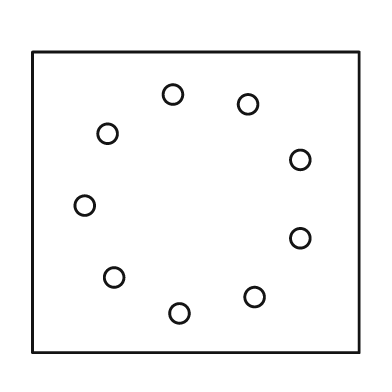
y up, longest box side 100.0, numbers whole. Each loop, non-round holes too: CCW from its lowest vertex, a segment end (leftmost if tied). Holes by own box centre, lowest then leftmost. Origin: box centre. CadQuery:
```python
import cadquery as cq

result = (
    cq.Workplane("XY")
    .moveTo(-50.0, -46.0)
    .lineTo(50.0, -46.0)
    .lineTo(50.0, 46.0)
    .lineTo(-50.0, 46.0)
    .close()
    .moveTo(-5.0, -34.0)
    .circle(3.0)
    .moveTo(18.0, -29.0)
    .circle(3.0)
    .moveTo(-25.0, -23.0)
    .circle(3.0)
    .moveTo(32.0, -11.0)
    .circle(3.0)
    .moveTo(-34.0, -1.0)
    .circle(3.0)
    .moveTo(32.0, 13.0)
    .circle(3.0)
    .moveTo(-27.0, 21.0)
    .circle(3.0)
    .moveTo(16.0, 30.0)
    .circle(3.0)
    .moveTo(-7.0, 33.0)
    .circle(3.0)
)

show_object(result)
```